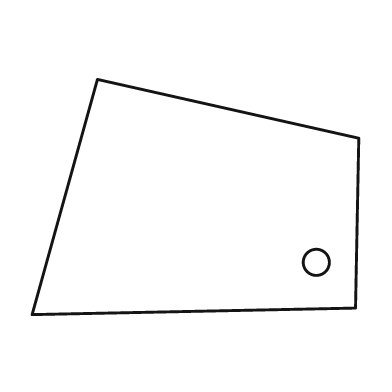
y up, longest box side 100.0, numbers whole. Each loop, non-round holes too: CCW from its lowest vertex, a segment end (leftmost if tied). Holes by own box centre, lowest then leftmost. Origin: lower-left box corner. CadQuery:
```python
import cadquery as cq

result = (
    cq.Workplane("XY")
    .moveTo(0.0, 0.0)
    .lineTo(99.0, 2.0)
    .lineTo(100.0, 54.0)
    .lineTo(20.0, 72.0)
    .close()
    .moveTo(87.0, 16.0)
    .circle(4.0)
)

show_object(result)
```